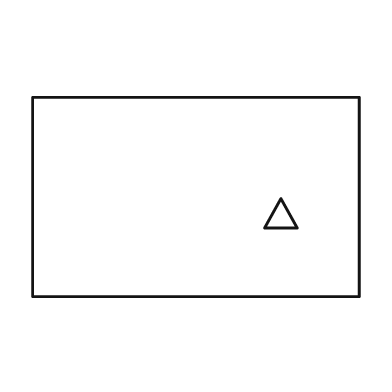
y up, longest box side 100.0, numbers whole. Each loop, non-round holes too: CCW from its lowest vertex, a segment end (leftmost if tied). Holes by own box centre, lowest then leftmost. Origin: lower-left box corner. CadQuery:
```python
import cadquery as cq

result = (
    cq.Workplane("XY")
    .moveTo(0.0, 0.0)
    .lineTo(100.0, 0.0)
    .lineTo(100.0, 61.0)
    .lineTo(0.0, 61.0)
    .close()
    .moveTo(71.0, 21.0)
    .lineTo(81.0, 21.0)
    .lineTo(76.0, 30.0)
    .close()
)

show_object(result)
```